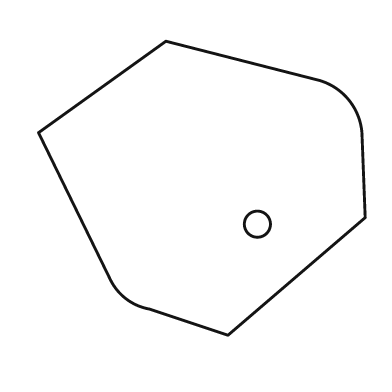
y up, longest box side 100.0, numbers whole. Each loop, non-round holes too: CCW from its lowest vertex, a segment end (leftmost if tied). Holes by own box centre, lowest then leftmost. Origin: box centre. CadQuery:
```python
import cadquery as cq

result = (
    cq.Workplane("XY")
    .moveTo(8.0, -45.0)
    .lineTo(50.0, -9.0)
    .lineTo(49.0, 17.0)
    .threePointArc((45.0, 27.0), (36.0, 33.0))
    .lineTo(-11.0, 45.0)
    .lineTo(-50.0, 17.0)
    .lineTo(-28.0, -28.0)
    .threePointArc((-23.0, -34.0), (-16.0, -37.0))
    .close()
    .moveTo(17.0, -11.0)
    .circle(4.0)
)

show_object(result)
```